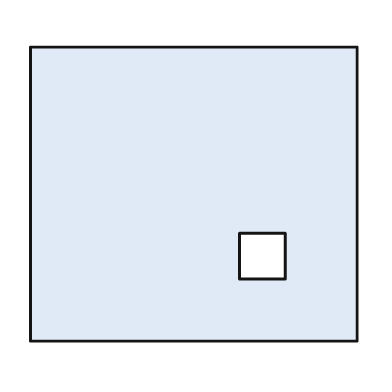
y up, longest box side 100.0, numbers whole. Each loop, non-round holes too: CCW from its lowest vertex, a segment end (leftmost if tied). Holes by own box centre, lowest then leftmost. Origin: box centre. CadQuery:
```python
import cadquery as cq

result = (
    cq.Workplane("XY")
    .moveTo(-50.0, -45.0)
    .lineTo(50.0, -45.0)
    .lineTo(50.0, 45.0)
    .lineTo(-50.0, 45.0)
    .close()
    .moveTo(14.0, -26.0)
    .lineTo(28.0, -26.0)
    .lineTo(28.0, -12.0)
    .lineTo(14.0, -12.0)
    .close()
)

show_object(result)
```